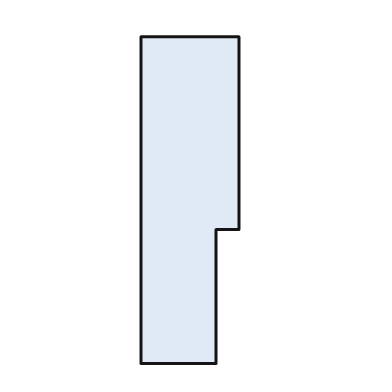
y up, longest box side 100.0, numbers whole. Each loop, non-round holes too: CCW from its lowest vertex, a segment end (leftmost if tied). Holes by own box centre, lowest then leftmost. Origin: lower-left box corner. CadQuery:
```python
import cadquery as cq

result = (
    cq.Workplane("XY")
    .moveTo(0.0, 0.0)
    .lineTo(23.0, 0.0)
    .lineTo(23.0, 41.0)
    .lineTo(30.0, 41.0)
    .lineTo(30.0, 100.0)
    .lineTo(0.0, 100.0)
    .close()
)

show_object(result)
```